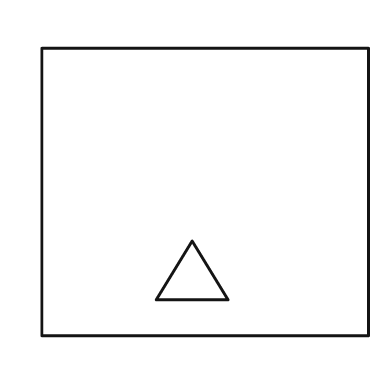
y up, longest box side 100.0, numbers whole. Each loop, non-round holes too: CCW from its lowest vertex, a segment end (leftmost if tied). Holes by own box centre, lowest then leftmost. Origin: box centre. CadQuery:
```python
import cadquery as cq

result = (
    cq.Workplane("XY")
    .moveTo(-50.0, -44.0)
    .lineTo(50.0, -44.0)
    .lineTo(50.0, 44.0)
    .lineTo(-50.0, 44.0)
    .close()
    .moveTo(-15.0, -33.0)
    .lineTo(7.0, -33.0)
    .lineTo(-4.0, -15.0)
    .close()
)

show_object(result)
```